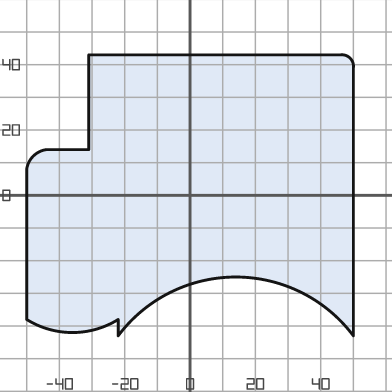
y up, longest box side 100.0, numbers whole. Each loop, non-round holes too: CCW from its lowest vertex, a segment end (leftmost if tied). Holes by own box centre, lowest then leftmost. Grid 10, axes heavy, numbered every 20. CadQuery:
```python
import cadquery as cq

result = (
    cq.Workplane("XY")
    .moveTo(-22.0, -43.0)
    .threePointArc((14.0, -25.0), (50.0, -43.0))
    .lineTo(50.0, 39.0)
    .threePointArc((49.0, 42.0), (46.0, 43.0))
    .lineTo(-31.0, 43.0)
    .lineTo(-31.0, 14.0)
    .lineTo(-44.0, 14.0)
    .threePointArc((-48.0, 12.0), (-50.0, 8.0))
    .lineTo(-50.0, -38.0)
    .threePointArc((-36.0, -42.0), (-22.0, -38.0))
    .close()
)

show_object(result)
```